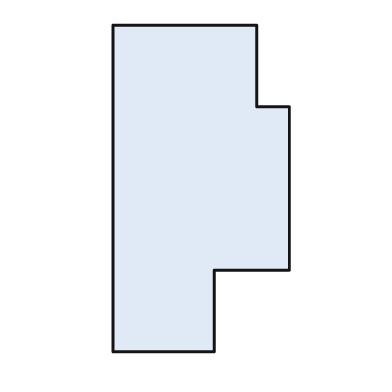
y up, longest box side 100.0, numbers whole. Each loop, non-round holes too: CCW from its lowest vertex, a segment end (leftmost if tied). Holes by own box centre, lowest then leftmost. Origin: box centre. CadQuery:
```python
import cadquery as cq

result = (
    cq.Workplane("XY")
    .moveTo(-27.0, -50.0)
    .lineTo(4.0, -50.0)
    .lineTo(4.0, -25.0)
    .lineTo(27.0, -25.0)
    .lineTo(27.0, 25.0)
    .lineTo(17.0, 25.0)
    .lineTo(17.0, 50.0)
    .lineTo(-27.0, 50.0)
    .close()
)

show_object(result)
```